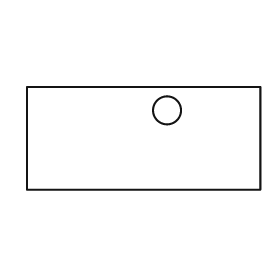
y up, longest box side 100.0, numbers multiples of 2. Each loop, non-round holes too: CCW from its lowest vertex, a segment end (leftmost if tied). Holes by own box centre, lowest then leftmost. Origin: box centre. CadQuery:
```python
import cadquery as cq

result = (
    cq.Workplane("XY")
    .moveTo(-50.0, -22.0)
    .lineTo(50.0, -22.0)
    .lineTo(50.0, 22.0)
    .lineTo(-50.0, 22.0)
    .close()
    .moveTo(10.0, 12.0)
    .circle(6.0)
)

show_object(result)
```